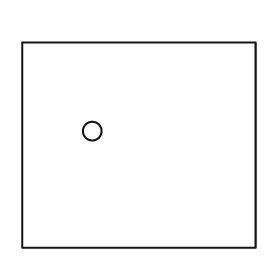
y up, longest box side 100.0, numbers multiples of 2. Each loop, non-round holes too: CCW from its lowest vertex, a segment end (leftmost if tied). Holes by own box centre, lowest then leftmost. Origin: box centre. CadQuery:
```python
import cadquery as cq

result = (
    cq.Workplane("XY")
    .moveTo(-50.0, -44.0)
    .lineTo(50.0, -44.0)
    .lineTo(50.0, 44.0)
    .lineTo(-50.0, 44.0)
    .close()
    .moveTo(-20.0, 6.0)
    .circle(4.0)
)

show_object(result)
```